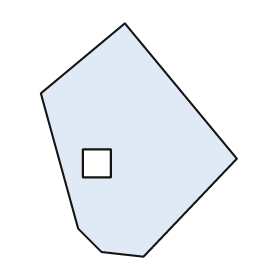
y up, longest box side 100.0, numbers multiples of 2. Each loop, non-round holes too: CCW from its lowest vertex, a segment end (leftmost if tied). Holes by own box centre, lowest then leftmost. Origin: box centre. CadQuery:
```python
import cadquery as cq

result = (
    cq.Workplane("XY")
    .moveTo(2.0, -50.0)
    .lineTo(42.0, -8.0)
    .lineTo(-6.0, 50.0)
    .lineTo(-42.0, 20.0)
    .lineTo(-26.0, -38.0)
    .lineTo(-16.0, -48.0)
    .close()
    .moveTo(-24.0, -16.0)
    .lineTo(-12.0, -16.0)
    .lineTo(-12.0, -4.0)
    .lineTo(-24.0, -4.0)
    .close()
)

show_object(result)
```